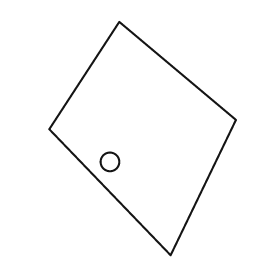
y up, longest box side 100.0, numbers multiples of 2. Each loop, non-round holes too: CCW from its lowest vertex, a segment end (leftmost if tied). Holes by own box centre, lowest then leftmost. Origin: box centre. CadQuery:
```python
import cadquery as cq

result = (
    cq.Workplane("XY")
    .moveTo(12.0, -50.0)
    .lineTo(40.0, 8.0)
    .lineTo(-10.0, 50.0)
    .lineTo(-40.0, 4.0)
    .close()
    .moveTo(-14.0, -10.0)
    .circle(4.0)
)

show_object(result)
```